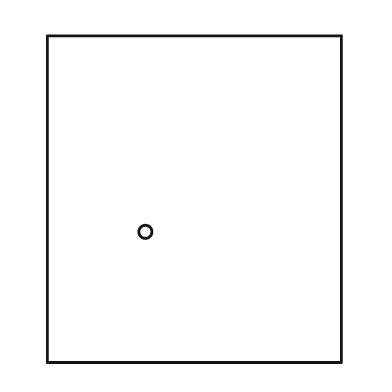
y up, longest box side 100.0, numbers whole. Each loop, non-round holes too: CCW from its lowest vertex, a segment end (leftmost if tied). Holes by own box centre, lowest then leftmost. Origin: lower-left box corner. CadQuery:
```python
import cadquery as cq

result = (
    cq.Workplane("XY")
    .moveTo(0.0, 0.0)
    .lineTo(90.0, 0.0)
    .lineTo(90.0, 100.0)
    .lineTo(0.0, 100.0)
    .close()
    .moveTo(30.0, 40.0)
    .circle(2.0)
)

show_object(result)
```